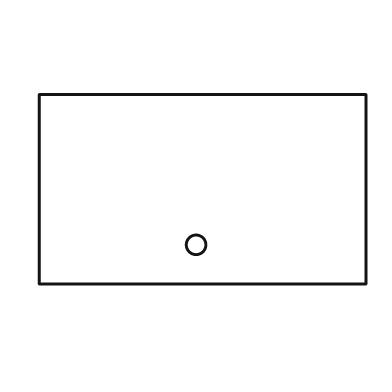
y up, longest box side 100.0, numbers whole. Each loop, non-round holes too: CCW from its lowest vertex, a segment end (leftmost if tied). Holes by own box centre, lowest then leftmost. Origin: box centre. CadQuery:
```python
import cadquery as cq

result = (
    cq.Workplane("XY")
    .moveTo(-50.0, -29.0)
    .lineTo(50.0, -29.0)
    .lineTo(50.0, 29.0)
    .lineTo(-50.0, 29.0)
    .close()
    .moveTo(-2.0, -17.0)
    .circle(3.0)
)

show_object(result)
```